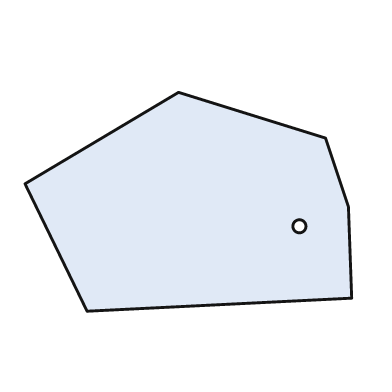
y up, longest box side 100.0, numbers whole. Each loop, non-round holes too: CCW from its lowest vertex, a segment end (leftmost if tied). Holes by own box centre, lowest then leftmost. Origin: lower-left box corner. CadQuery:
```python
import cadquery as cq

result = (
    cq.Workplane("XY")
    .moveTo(19.0, 0.0)
    .lineTo(100.0, 4.0)
    .lineTo(99.0, 32.0)
    .lineTo(92.0, 53.0)
    .lineTo(47.0, 67.0)
    .lineTo(0.0, 39.0)
    .close()
    .moveTo(84.0, 26.0)
    .circle(2.0)
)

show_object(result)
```